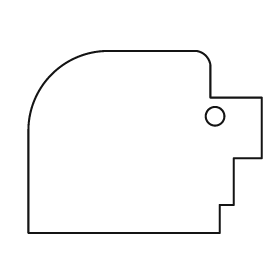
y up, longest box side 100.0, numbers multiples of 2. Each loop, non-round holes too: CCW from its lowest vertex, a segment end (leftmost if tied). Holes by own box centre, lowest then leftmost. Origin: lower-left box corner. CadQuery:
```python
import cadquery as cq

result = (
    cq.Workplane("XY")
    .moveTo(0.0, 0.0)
    .lineTo(82.0, 0.0)
    .lineTo(82.0, 12.0)
    .lineTo(88.0, 12.0)
    .lineTo(88.0, 32.0)
    .lineTo(100.0, 32.0)
    .lineTo(100.0, 58.0)
    .lineTo(78.0, 58.0)
    .lineTo(78.0, 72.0)
    .threePointArc((76.0, 76.0), (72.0, 78.0))
    .lineTo(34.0, 78.0)
    .threePointArc((10.0, 68.0), (0.0, 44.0))
    .close()
    .moveTo(80.0, 50.0)
    .circle(4.0)
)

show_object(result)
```